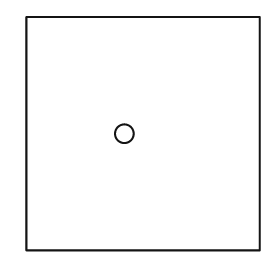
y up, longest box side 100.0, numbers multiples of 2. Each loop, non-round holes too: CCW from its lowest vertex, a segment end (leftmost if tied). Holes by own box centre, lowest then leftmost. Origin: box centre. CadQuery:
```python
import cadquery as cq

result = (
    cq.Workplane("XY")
    .moveTo(-50.0, -50.0)
    .lineTo(50.0, -50.0)
    .lineTo(50.0, 50.0)
    .lineTo(-50.0, 50.0)
    .close()
    .moveTo(-8.0, 0.0)
    .circle(4.0)
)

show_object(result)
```